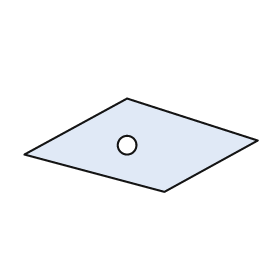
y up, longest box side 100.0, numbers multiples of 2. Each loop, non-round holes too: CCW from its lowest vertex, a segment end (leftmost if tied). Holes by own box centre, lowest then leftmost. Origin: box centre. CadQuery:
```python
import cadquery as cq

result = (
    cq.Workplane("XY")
    .moveTo(10.0, -20.0)
    .lineTo(50.0, 2.0)
    .lineTo(-6.0, 20.0)
    .lineTo(-50.0, -4.0)
    .close()
    .moveTo(-6.0, 0.0)
    .circle(4.0)
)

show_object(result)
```